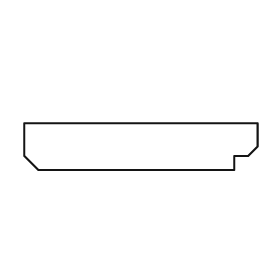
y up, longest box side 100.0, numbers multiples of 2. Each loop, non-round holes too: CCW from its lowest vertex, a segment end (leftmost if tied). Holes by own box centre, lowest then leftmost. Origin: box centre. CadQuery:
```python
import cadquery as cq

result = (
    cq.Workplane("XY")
    .moveTo(-44.0, -10.0)
    .lineTo(40.0, -10.0)
    .lineTo(40.0, -4.0)
    .lineTo(46.0, -4.0)
    .lineTo(50.0, 0.0)
    .lineTo(50.0, 10.0)
    .lineTo(-50.0, 10.0)
    .lineTo(-50.0, -4.0)
    .close()
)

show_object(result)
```